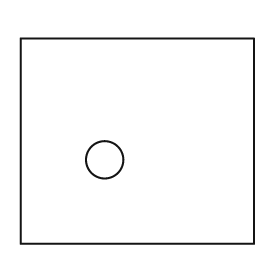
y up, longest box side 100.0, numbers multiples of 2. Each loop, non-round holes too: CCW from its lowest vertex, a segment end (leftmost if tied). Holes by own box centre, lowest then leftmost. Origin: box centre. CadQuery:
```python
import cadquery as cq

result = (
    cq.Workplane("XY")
    .moveTo(-50.0, -44.0)
    .lineTo(50.0, -44.0)
    .lineTo(50.0, 44.0)
    .lineTo(-50.0, 44.0)
    .close()
    .moveTo(-14.0, -8.0)
    .circle(8.0)
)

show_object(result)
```